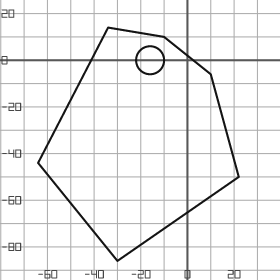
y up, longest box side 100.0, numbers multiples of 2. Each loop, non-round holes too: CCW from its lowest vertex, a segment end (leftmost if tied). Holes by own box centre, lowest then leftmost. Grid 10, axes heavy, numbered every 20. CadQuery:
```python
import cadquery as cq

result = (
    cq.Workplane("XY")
    .moveTo(-30.0, -86.0)
    .lineTo(22.0, -50.0)
    .lineTo(10.0, -6.0)
    .lineTo(-10.0, 10.0)
    .lineTo(-34.0, 14.0)
    .lineTo(-64.0, -44.0)
    .close()
    .moveTo(-16.0, 0.0)
    .circle(6.0)
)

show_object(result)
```